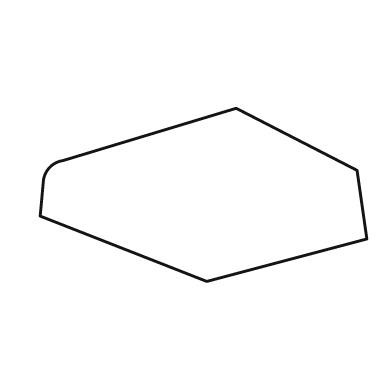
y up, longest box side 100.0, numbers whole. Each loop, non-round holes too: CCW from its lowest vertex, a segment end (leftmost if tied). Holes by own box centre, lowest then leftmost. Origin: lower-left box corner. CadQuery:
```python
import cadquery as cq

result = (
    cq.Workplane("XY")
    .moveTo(51.0, 0.0)
    .lineTo(100.0, 13.0)
    .lineTo(97.0, 34.0)
    .lineTo(60.0, 53.0)
    .lineTo(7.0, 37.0)
    .threePointArc((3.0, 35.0), (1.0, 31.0))
    .lineTo(0.0, 20.0)
    .close()
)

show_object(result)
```